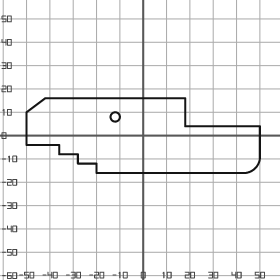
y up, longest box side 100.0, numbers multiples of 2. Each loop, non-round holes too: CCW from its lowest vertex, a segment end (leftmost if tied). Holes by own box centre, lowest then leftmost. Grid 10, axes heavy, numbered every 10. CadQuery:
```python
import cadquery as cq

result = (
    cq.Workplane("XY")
    .moveTo(-20.0, -16.0)
    .lineTo(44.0, -16.0)
    .threePointArc((48.0, -14.0), (50.0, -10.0))
    .lineTo(50.0, 4.0)
    .lineTo(18.0, 4.0)
    .lineTo(18.0, 16.0)
    .lineTo(-42.0, 16.0)
    .lineTo(-50.0, 10.0)
    .lineTo(-50.0, -4.0)
    .lineTo(-36.0, -4.0)
    .lineTo(-36.0, -8.0)
    .lineTo(-28.0, -8.0)
    .lineTo(-28.0, -12.0)
    .lineTo(-20.0, -12.0)
    .close()
    .moveTo(-12.0, 8.0)
    .circle(2.0)
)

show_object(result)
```